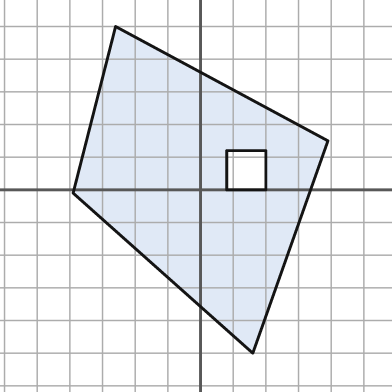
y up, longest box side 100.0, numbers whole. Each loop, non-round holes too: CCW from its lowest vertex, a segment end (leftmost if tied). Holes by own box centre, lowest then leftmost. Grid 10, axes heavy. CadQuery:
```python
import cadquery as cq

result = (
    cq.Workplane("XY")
    .moveTo(16.0, -50.0)
    .lineTo(39.0, 15.0)
    .lineTo(-26.0, 50.0)
    .lineTo(-39.0, -1.0)
    .close()
    .moveTo(8.0, 0.0)
    .lineTo(20.0, 0.0)
    .lineTo(20.0, 12.0)
    .lineTo(8.0, 12.0)
    .close()
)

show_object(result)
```